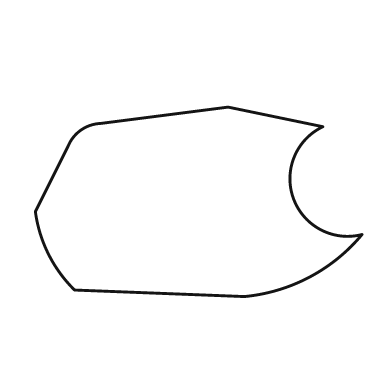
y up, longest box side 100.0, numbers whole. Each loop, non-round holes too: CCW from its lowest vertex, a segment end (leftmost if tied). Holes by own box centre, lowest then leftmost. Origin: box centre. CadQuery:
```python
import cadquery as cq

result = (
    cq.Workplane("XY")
    .moveTo(14.0, -29.0)
    .threePointArc((34.0, -23.0), (50.0, -10.0))
    .threePointArc((29.0, 1.0), (38.0, 23.0))
    .lineTo(9.0, 29.0)
    .lineTo(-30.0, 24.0)
    .threePointArc((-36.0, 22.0), (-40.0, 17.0))
    .lineTo(-50.0, -3.0)
    .threePointArc((-46.0, -16.0), (-38.0, -27.0))
    .close()
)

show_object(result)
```